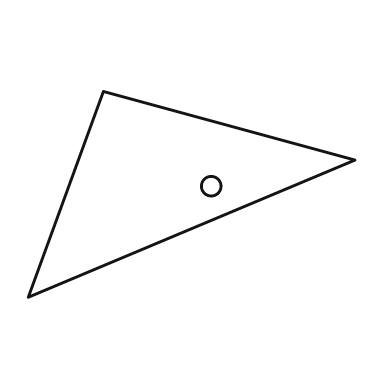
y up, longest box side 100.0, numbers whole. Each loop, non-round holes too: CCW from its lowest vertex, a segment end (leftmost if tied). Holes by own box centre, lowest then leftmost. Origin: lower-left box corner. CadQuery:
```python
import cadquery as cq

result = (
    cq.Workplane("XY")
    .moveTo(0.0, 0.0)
    .lineTo(100.0, 42.0)
    .lineTo(23.0, 63.0)
    .close()
    .moveTo(56.0, 34.0)
    .circle(3.0)
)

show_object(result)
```